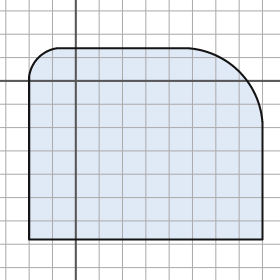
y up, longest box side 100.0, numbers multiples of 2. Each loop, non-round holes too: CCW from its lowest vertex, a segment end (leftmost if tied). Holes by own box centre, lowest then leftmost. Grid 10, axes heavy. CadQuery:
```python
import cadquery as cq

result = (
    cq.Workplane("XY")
    .moveTo(-20.0, -68.0)
    .lineTo(80.0, -68.0)
    .lineTo(80.0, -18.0)
    .threePointArc((70.0, 4.0), (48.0, 14.0))
    .lineTo(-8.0, 14.0)
    .threePointArc((-16.0, 10.0), (-20.0, 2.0))
    .close()
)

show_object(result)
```